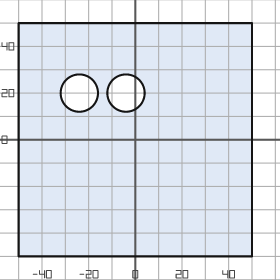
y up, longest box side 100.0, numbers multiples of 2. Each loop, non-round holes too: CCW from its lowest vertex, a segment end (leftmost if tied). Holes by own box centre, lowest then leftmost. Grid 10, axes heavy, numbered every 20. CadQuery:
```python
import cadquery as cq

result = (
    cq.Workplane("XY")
    .moveTo(-50.0, -50.0)
    .lineTo(50.0, -50.0)
    .lineTo(50.0, 50.0)
    .lineTo(-50.0, 50.0)
    .close()
    .moveTo(-24.0, 20.0)
    .circle(8.0)
    .moveTo(-4.0, 20.0)
    .circle(8.0)
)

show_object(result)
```